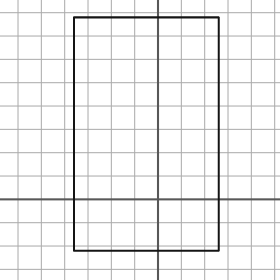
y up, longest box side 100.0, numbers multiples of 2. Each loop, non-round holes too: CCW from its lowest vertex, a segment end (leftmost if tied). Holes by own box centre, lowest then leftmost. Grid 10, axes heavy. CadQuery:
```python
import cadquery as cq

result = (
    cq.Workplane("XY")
    .moveTo(-36.0, -22.0)
    .lineTo(26.0, -22.0)
    .lineTo(26.0, 78.0)
    .lineTo(-36.0, 78.0)
    .close()
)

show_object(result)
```